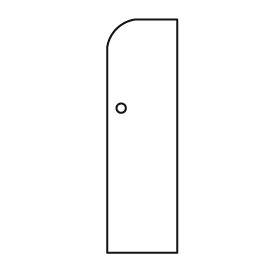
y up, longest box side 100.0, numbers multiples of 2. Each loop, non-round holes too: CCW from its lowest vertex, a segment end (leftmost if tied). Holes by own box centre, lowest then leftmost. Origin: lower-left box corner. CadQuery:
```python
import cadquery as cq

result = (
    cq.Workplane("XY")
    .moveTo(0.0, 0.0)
    .lineTo(30.0, 0.0)
    .lineTo(30.0, 100.0)
    .lineTo(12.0, 100.0)
    .threePointArc((4.0, 96.0), (0.0, 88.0))
    .close()
    .moveTo(6.0, 62.0)
    .circle(2.0)
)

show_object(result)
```